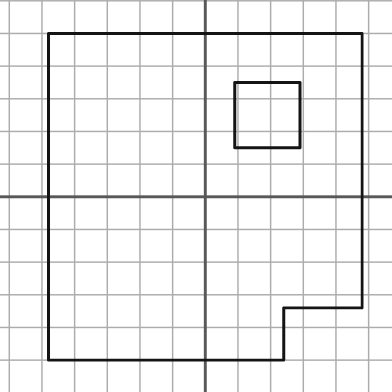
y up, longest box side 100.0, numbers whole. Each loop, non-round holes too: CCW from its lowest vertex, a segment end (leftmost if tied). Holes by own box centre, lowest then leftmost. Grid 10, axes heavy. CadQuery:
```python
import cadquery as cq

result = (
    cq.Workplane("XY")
    .moveTo(-48.0, -50.0)
    .lineTo(24.0, -50.0)
    .lineTo(24.0, -34.0)
    .lineTo(48.0, -34.0)
    .lineTo(48.0, 50.0)
    .lineTo(-48.0, 50.0)
    .close()
    .moveTo(9.0, 15.0)
    .lineTo(29.0, 15.0)
    .lineTo(29.0, 35.0)
    .lineTo(9.0, 35.0)
    .close()
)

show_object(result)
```